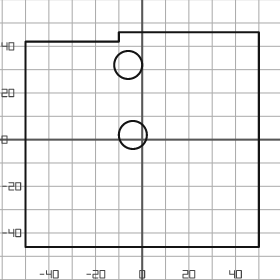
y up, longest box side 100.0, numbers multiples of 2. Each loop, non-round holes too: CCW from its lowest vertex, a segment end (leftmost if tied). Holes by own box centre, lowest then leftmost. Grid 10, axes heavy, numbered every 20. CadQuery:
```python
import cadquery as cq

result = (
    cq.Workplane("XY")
    .moveTo(-50.0, -46.0)
    .lineTo(50.0, -46.0)
    .lineTo(50.0, 46.0)
    .lineTo(-10.0, 46.0)
    .lineTo(-10.0, 42.0)
    .lineTo(-50.0, 42.0)
    .close()
    .moveTo(-4.0, 2.0)
    .circle(6.0)
    .moveTo(-6.0, 32.0)
    .circle(6.0)
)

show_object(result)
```